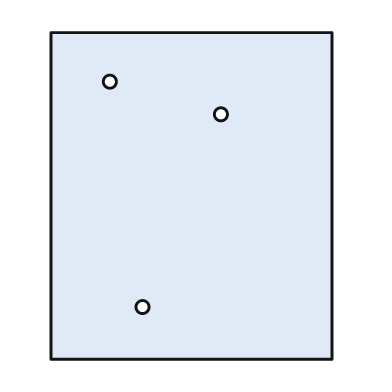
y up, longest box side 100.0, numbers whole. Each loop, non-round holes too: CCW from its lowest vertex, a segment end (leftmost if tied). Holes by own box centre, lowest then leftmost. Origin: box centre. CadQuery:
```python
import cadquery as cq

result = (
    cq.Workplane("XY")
    .moveTo(-43.0, -50.0)
    .lineTo(43.0, -50.0)
    .lineTo(43.0, 50.0)
    .lineTo(-43.0, 50.0)
    .close()
    .moveTo(-15.0, -34.0)
    .circle(2.0)
    .moveTo(9.0, 25.0)
    .circle(2.0)
    .moveTo(-25.0, 35.0)
    .circle(2.0)
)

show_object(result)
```